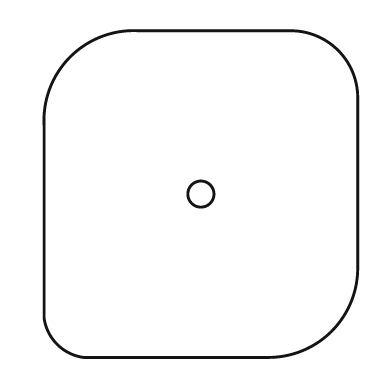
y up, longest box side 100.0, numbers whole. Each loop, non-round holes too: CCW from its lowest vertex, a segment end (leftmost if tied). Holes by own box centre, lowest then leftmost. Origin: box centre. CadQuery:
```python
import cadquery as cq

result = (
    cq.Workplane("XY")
    .moveTo(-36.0, -50.0)
    .lineTo(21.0, -50.0)
    .threePointArc((40.0, -42.0), (48.0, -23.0))
    .lineTo(48.0, 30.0)
    .threePointArc((42.0, 44.0), (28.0, 50.0))
    .lineTo(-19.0, 50.0)
    .threePointArc((-40.0, 42.0), (-48.0, 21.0))
    .lineTo(-48.0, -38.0)
    .threePointArc((-44.0, -46.0), (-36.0, -50.0))
    .close()
    .moveTo(0.0, 0.0)
    .circle(4.0)
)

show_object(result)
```